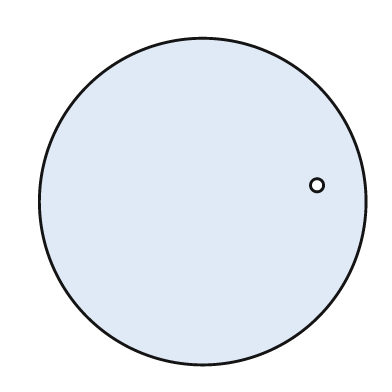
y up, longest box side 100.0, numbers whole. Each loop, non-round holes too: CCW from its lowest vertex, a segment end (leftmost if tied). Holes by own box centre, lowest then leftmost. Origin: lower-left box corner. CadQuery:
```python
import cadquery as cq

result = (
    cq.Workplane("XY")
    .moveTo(50.0, 50.0)
    .circle(50.0)
    .moveTo(85.0, 55.0)
    .circle(2.0)
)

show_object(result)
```